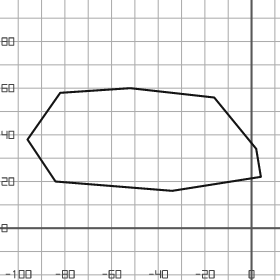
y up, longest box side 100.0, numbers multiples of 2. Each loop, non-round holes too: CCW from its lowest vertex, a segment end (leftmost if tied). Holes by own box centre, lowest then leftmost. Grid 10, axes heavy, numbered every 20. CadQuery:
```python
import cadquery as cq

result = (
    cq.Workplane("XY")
    .moveTo(-34.0, 16.0)
    .lineTo(4.0, 22.0)
    .lineTo(2.0, 34.0)
    .lineTo(-16.0, 56.0)
    .lineTo(-52.0, 60.0)
    .lineTo(-82.0, 58.0)
    .lineTo(-96.0, 38.0)
    .lineTo(-84.0, 20.0)
    .close()
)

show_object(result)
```